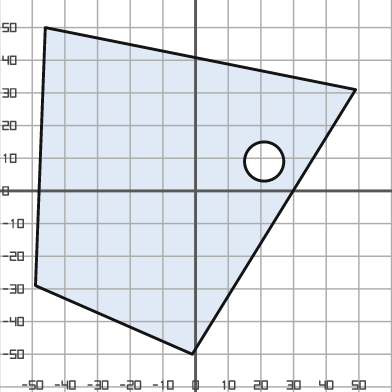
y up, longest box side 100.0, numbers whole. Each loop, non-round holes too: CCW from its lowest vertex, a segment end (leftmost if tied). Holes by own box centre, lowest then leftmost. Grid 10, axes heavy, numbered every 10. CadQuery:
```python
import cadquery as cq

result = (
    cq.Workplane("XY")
    .moveTo(-1.0, -50.0)
    .lineTo(49.0, 31.0)
    .lineTo(-46.0, 50.0)
    .lineTo(-49.0, -29.0)
    .close()
    .moveTo(21.0, 9.0)
    .circle(6.0)
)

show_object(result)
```